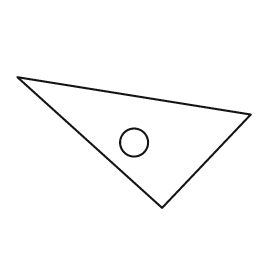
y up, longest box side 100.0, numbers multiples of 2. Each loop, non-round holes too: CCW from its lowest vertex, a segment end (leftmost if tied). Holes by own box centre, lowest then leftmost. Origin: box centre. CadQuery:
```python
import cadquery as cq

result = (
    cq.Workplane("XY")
    .moveTo(12.0, -28.0)
    .lineTo(50.0, 12.0)
    .lineTo(-50.0, 28.0)
    .close()
    .moveTo(0.0, 0.0)
    .circle(6.0)
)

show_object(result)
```